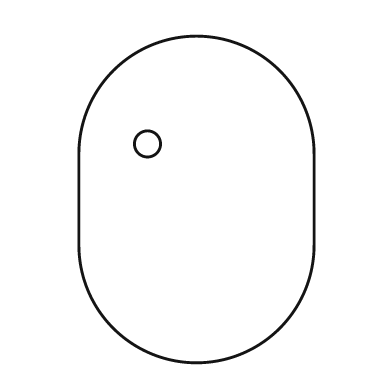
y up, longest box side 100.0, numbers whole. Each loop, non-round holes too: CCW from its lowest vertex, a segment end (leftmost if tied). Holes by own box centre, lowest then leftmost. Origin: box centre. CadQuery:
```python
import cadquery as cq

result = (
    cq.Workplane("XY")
    .moveTo(-36.0, -14.0)
    .threePointArc((0.0, -50.0), (36.0, -14.0))
    .lineTo(36.0, 14.0)
    .threePointArc((0.0, 50.0), (-36.0, 14.0))
    .close()
    .moveTo(-15.0, 17.0)
    .circle(4.0)
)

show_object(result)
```